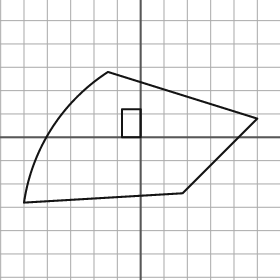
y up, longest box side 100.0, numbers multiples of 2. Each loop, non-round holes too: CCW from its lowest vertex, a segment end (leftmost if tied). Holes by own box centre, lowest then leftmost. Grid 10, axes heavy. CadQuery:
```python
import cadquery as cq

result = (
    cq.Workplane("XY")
    .moveTo(-50.0, -28.0)
    .lineTo(18.0, -24.0)
    .lineTo(50.0, 8.0)
    .lineTo(-14.0, 28.0)
    .threePointArc((-38.0, 4.0), (-50.0, -28.0))
    .close()
    .moveTo(-8.0, 0.0)
    .lineTo(0.0, 0.0)
    .lineTo(0.0, 12.0)
    .lineTo(-8.0, 12.0)
    .close()
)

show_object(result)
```